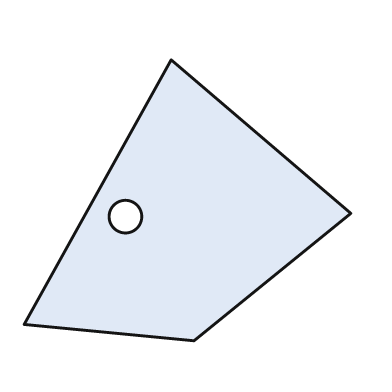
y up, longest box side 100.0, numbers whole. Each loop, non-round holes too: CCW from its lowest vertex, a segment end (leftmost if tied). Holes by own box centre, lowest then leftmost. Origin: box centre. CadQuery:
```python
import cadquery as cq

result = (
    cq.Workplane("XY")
    .moveTo(2.0, -43.0)
    .lineTo(50.0, -4.0)
    .lineTo(-5.0, 43.0)
    .lineTo(-50.0, -38.0)
    .close()
    .moveTo(-19.0, -5.0)
    .circle(5.0)
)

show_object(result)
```